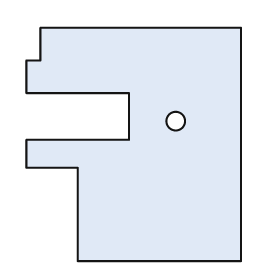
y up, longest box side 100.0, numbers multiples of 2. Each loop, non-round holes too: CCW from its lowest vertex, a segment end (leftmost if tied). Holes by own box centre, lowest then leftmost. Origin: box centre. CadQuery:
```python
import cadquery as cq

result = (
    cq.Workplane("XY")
    .moveTo(-24.0, -50.0)
    .lineTo(46.0, -50.0)
    .lineTo(46.0, 50.0)
    .lineTo(-40.0, 50.0)
    .lineTo(-40.0, 36.0)
    .lineTo(-46.0, 36.0)
    .lineTo(-46.0, 22.0)
    .lineTo(-2.0, 22.0)
    .lineTo(-2.0, 2.0)
    .lineTo(-46.0, 2.0)
    .lineTo(-46.0, -10.0)
    .lineTo(-24.0, -10.0)
    .close()
    .moveTo(18.0, 10.0)
    .circle(4.0)
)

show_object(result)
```